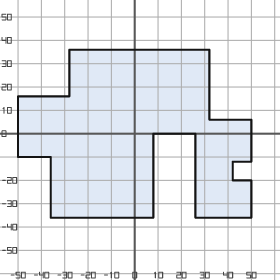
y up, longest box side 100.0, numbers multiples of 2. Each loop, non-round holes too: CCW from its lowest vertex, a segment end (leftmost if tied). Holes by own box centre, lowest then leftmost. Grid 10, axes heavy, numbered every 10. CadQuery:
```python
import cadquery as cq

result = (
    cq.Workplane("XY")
    .moveTo(-36.0, -36.0)
    .lineTo(8.0, -36.0)
    .lineTo(8.0, 0.0)
    .lineTo(26.0, 0.0)
    .lineTo(26.0, -36.0)
    .lineTo(50.0, -36.0)
    .lineTo(50.0, -20.0)
    .lineTo(42.0, -20.0)
    .lineTo(42.0, -12.0)
    .lineTo(50.0, -12.0)
    .lineTo(50.0, 6.0)
    .lineTo(32.0, 6.0)
    .lineTo(32.0, 36.0)
    .lineTo(-28.0, 36.0)
    .lineTo(-28.0, 16.0)
    .lineTo(-50.0, 16.0)
    .lineTo(-50.0, -10.0)
    .lineTo(-36.0, -10.0)
    .close()
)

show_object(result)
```